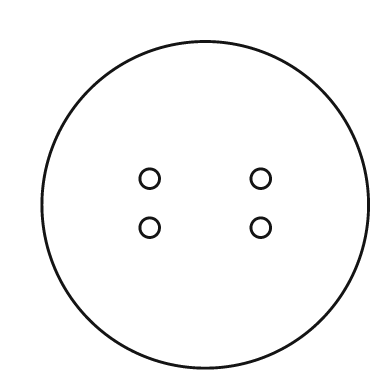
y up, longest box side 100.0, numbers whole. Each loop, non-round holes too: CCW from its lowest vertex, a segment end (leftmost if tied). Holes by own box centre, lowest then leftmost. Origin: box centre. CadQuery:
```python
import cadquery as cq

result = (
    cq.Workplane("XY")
    .moveTo(0.0, 0.0)
    .circle(50.0)
    .moveTo(-17.0, -7.0)
    .circle(3.0)
    .moveTo(17.0, -7.0)
    .circle(3.0)
    .moveTo(-17.0, 8.0)
    .circle(3.0)
    .moveTo(17.0, 8.0)
    .circle(3.0)
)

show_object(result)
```